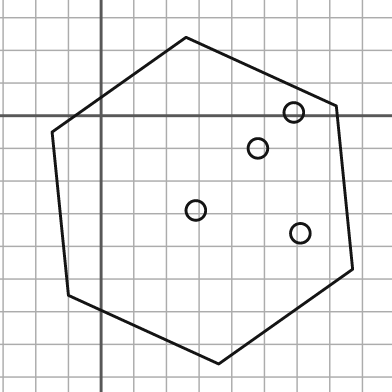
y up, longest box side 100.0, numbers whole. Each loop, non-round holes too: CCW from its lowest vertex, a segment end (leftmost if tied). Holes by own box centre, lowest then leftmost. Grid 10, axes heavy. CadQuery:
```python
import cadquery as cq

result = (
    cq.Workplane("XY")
    .moveTo(36.0, -76.0)
    .lineTo(77.0, -47.0)
    .lineTo(72.0, 3.0)
    .lineTo(26.0, 24.0)
    .lineTo(-15.0, -5.0)
    .lineTo(-10.0, -55.0)
    .close()
    .moveTo(61.0, -36.0)
    .circle(3.0)
    .moveTo(29.0, -29.0)
    .circle(3.0)
    .moveTo(48.0, -10.0)
    .circle(3.0)
    .moveTo(59.0, 1.0)
    .circle(3.0)
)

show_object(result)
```